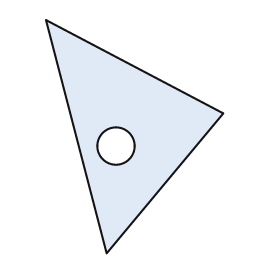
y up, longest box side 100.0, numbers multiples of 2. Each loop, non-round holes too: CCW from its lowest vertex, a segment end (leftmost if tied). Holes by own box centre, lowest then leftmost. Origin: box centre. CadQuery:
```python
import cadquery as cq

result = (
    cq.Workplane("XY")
    .moveTo(-12.0, -50.0)
    .lineTo(38.0, 10.0)
    .lineTo(-38.0, 50.0)
    .close()
    .moveTo(-8.0, -4.0)
    .circle(8.0)
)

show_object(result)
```